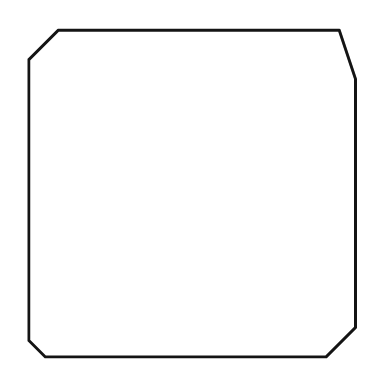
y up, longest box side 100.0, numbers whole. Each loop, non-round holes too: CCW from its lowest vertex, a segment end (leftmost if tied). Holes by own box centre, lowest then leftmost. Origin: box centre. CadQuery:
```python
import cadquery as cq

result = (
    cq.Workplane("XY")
    .moveTo(-45.0, -50.0)
    .lineTo(41.0, -50.0)
    .lineTo(50.0, -41.0)
    .lineTo(50.0, 35.0)
    .lineTo(45.0, 50.0)
    .lineTo(-41.0, 50.0)
    .lineTo(-50.0, 41.0)
    .lineTo(-50.0, -45.0)
    .close()
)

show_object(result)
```